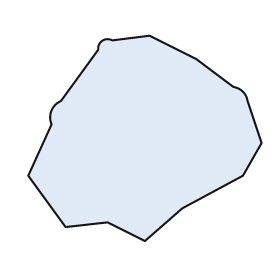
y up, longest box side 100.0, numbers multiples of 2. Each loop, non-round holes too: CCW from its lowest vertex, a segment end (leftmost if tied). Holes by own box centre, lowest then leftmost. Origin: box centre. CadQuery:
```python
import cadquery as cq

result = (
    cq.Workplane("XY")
    .moveTo(0.0, -44.0)
    .lineTo(16.0, -30.0)
    .lineTo(42.0, -16.0)
    .lineTo(50.0, -2.0)
    .lineTo(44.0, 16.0)
    .threePointArc((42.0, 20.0), (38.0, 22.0))
    .lineTo(22.0, 34.0)
    .lineTo(2.0, 44.0)
    .lineTo(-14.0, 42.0)
    .threePointArc((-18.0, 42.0), (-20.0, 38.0))
    .lineTo(-36.0, 16.0)
    .threePointArc((-40.0, 12.0), (-40.0, 6.0))
    .lineTo(-50.0, -16.0)
    .lineTo(-34.0, -38.0)
    .lineTo(-16.0, -36.0)
    .close()
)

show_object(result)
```